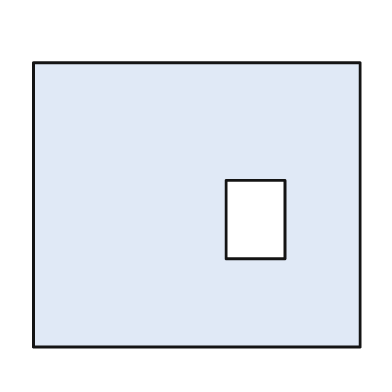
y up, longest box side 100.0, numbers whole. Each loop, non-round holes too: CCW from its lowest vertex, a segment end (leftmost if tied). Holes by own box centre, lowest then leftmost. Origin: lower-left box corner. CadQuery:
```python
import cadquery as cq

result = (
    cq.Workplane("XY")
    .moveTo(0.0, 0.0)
    .lineTo(100.0, 0.0)
    .lineTo(100.0, 87.0)
    .lineTo(0.0, 87.0)
    .close()
    .moveTo(59.0, 27.0)
    .lineTo(77.0, 27.0)
    .lineTo(77.0, 51.0)
    .lineTo(59.0, 51.0)
    .close()
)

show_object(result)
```